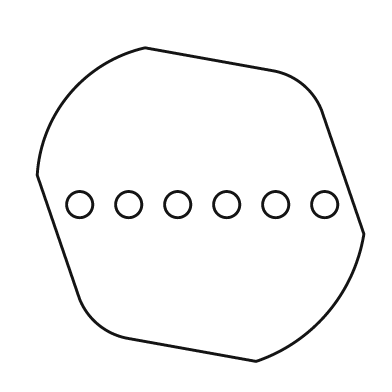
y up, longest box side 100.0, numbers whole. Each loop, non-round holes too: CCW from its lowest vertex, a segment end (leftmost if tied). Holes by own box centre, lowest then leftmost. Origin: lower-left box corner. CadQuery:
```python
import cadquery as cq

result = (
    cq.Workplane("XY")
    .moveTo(67.0, 0.0)
    .threePointArc((89.0, 15.0), (100.0, 39.0))
    .lineTo(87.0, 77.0)
    .threePointArc((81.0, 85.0), (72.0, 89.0))
    .lineTo(33.0, 96.0)
    .threePointArc((10.0, 82.0), (0.0, 57.0))
    .lineTo(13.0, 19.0)
    .threePointArc((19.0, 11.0), (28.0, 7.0))
    .close()
    .moveTo(13.0, 48.0)
    .circle(4.0)
    .moveTo(28.0, 48.0)
    .circle(4.0)
    .moveTo(43.0, 48.0)
    .circle(4.0)
    .moveTo(58.0, 48.0)
    .circle(4.0)
    .moveTo(73.0, 48.0)
    .circle(4.0)
    .moveTo(88.0, 48.0)
    .circle(4.0)
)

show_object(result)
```